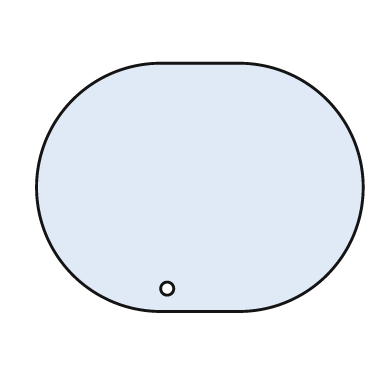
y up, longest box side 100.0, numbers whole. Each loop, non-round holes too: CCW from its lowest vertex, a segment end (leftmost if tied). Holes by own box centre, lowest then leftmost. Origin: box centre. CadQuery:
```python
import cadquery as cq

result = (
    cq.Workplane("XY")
    .moveTo(-12.0, -38.0)
    .lineTo(12.0, -38.0)
    .threePointArc((50.0, 0.0), (12.0, 38.0))
    .lineTo(-12.0, 38.0)
    .threePointArc((-50.0, 0.0), (-12.0, -38.0))
    .close()
    .moveTo(-10.0, -31.0)
    .circle(2.0)
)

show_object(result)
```